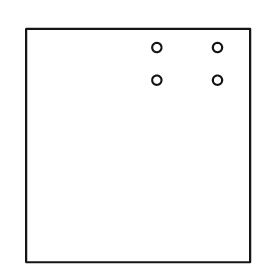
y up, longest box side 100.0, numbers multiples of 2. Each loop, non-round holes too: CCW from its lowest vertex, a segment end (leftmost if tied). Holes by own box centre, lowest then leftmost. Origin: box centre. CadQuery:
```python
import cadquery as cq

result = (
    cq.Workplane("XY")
    .moveTo(-48.0, -50.0)
    .lineTo(48.0, -50.0)
    .lineTo(48.0, 50.0)
    .lineTo(-48.0, 50.0)
    .close()
    .moveTo(8.0, 28.0)
    .circle(2.0)
    .moveTo(34.0, 28.0)
    .circle(2.0)
    .moveTo(8.0, 42.0)
    .circle(2.0)
    .moveTo(34.0, 42.0)
    .circle(2.0)
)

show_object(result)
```